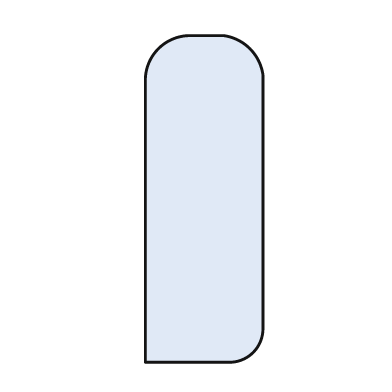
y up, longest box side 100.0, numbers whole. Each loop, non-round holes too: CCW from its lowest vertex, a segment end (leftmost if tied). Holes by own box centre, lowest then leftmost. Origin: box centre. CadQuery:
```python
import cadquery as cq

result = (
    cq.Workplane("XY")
    .moveTo(-18.0, -50.0)
    .lineTo(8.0, -50.0)
    .threePointArc((15.0, -47.0), (18.0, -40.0))
    .lineTo(18.0, 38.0)
    .threePointArc((14.0, 46.0), (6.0, 50.0))
    .lineTo(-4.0, 50.0)
    .threePointArc((-14.0, 46.0), (-18.0, 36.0))
    .close()
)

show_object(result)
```